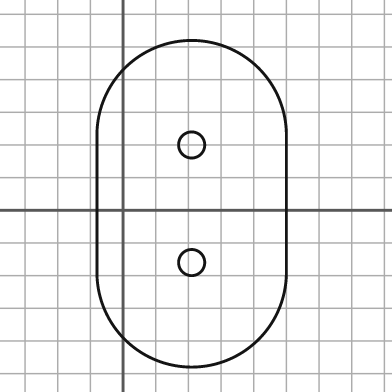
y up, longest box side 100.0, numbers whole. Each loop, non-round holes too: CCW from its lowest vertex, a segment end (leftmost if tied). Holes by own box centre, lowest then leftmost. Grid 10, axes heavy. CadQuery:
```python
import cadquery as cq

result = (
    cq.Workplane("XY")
    .moveTo(-8.0, -19.0)
    .threePointArc((21.0, -48.0), (50.0, -19.0))
    .lineTo(50.0, 23.0)
    .threePointArc((21.0, 52.0), (-8.0, 23.0))
    .close()
    .moveTo(21.0, -16.0)
    .circle(4.0)
    .moveTo(21.0, 20.0)
    .circle(4.0)
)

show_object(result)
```